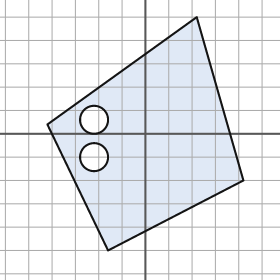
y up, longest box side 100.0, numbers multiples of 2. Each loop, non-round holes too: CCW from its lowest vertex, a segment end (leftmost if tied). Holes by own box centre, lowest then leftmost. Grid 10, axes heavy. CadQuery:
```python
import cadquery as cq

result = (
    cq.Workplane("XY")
    .moveTo(-16.0, -50.0)
    .lineTo(42.0, -20.0)
    .lineTo(22.0, 50.0)
    .lineTo(-42.0, 4.0)
    .close()
    .moveTo(-22.0, -10.0)
    .circle(6.0)
    .moveTo(-22.0, 6.0)
    .circle(6.0)
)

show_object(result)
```